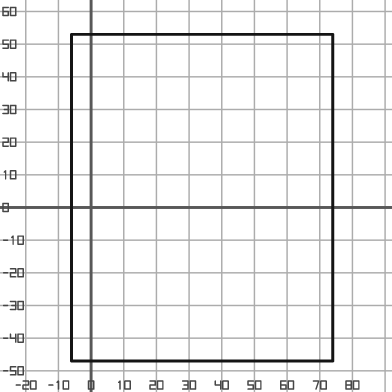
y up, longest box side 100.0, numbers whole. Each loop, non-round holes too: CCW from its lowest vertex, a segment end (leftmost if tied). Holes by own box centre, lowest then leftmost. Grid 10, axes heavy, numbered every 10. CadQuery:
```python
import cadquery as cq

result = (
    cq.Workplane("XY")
    .moveTo(-6.0, -47.0)
    .lineTo(74.0, -47.0)
    .lineTo(74.0, 53.0)
    .lineTo(-6.0, 53.0)
    .close()
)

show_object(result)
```